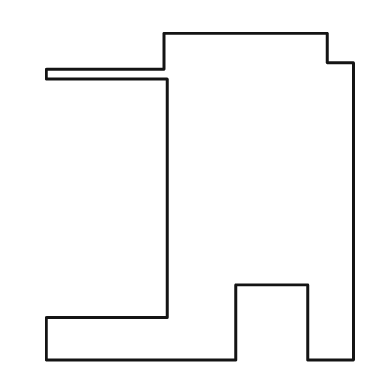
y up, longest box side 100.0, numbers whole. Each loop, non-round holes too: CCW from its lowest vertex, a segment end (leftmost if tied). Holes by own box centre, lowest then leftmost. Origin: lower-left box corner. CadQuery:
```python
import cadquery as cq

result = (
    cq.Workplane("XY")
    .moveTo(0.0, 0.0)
    .lineTo(58.0, 0.0)
    .lineTo(58.0, 23.0)
    .lineTo(80.0, 23.0)
    .lineTo(80.0, 0.0)
    .lineTo(94.0, 0.0)
    .lineTo(94.0, 91.0)
    .lineTo(86.0, 91.0)
    .lineTo(86.0, 100.0)
    .lineTo(36.0, 100.0)
    .lineTo(36.0, 89.0)
    .lineTo(0.0, 89.0)
    .lineTo(0.0, 86.0)
    .lineTo(37.0, 86.0)
    .lineTo(37.0, 13.0)
    .lineTo(0.0, 13.0)
    .close()
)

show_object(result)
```